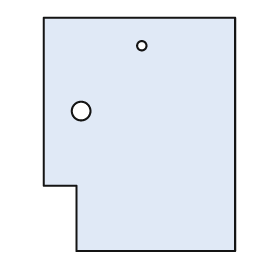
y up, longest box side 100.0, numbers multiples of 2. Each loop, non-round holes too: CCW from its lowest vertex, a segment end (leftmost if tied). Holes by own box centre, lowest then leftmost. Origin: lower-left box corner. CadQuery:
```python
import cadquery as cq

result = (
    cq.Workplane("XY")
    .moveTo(14.0, 0.0)
    .lineTo(82.0, 0.0)
    .lineTo(82.0, 100.0)
    .lineTo(0.0, 100.0)
    .lineTo(0.0, 28.0)
    .lineTo(14.0, 28.0)
    .close()
    .moveTo(16.0, 60.0)
    .circle(4.0)
    .moveTo(42.0, 88.0)
    .circle(2.0)
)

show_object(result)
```